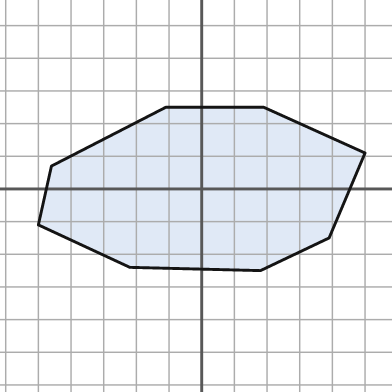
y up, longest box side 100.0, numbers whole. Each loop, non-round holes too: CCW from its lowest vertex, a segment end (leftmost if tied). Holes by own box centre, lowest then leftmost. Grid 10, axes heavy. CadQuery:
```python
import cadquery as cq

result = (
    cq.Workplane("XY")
    .moveTo(18.0, -25.0)
    .lineTo(39.0, -15.0)
    .lineTo(50.0, 11.0)
    .lineTo(19.0, 25.0)
    .lineTo(-11.0, 25.0)
    .lineTo(-46.0, 7.0)
    .lineTo(-50.0, -11.0)
    .lineTo(-22.0, -24.0)
    .close()
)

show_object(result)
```